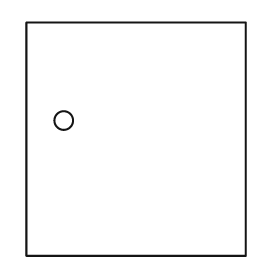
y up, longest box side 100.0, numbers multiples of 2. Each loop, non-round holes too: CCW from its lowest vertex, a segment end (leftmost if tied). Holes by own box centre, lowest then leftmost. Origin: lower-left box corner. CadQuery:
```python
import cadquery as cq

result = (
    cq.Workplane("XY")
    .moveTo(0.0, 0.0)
    .lineTo(94.0, 0.0)
    .lineTo(94.0, 100.0)
    .lineTo(0.0, 100.0)
    .close()
    .moveTo(16.0, 58.0)
    .circle(4.0)
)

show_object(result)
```